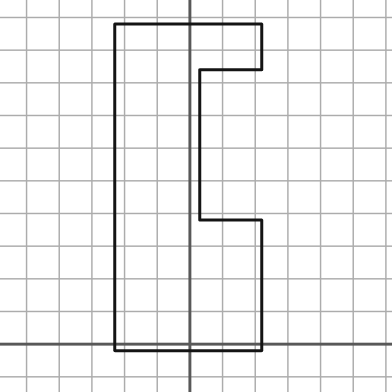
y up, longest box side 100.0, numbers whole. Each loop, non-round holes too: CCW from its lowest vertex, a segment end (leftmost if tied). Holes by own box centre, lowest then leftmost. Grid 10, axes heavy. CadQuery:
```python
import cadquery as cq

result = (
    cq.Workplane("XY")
    .moveTo(-23.0, -2.0)
    .lineTo(22.0, -2.0)
    .lineTo(22.0, 38.0)
    .lineTo(3.0, 38.0)
    .lineTo(3.0, 84.0)
    .lineTo(22.0, 84.0)
    .lineTo(22.0, 98.0)
    .lineTo(-23.0, 98.0)
    .close()
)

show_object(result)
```